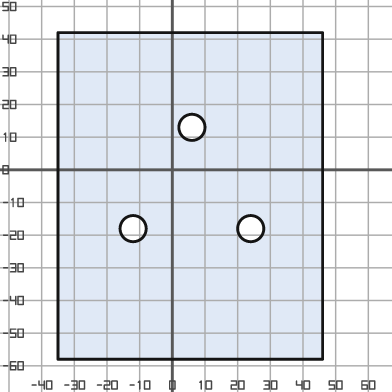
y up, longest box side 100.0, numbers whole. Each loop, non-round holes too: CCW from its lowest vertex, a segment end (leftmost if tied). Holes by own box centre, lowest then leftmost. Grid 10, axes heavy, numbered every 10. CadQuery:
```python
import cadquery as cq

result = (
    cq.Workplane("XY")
    .moveTo(-35.0, -58.0)
    .lineTo(46.0, -58.0)
    .lineTo(46.0, 42.0)
    .lineTo(-35.0, 42.0)
    .close()
    .moveTo(-12.0, -18.0)
    .circle(4.0)
    .moveTo(24.0, -18.0)
    .circle(4.0)
    .moveTo(6.0, 13.0)
    .circle(4.0)
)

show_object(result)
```